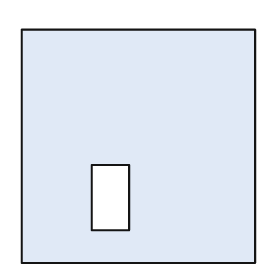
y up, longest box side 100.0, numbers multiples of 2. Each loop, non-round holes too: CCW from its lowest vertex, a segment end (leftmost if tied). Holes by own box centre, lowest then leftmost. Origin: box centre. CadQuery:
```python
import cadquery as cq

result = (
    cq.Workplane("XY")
    .moveTo(-50.0, -50.0)
    .lineTo(50.0, -50.0)
    .lineTo(50.0, 50.0)
    .lineTo(-50.0, 50.0)
    .close()
    .moveTo(-20.0, -36.0)
    .lineTo(-4.0, -36.0)
    .lineTo(-4.0, -8.0)
    .lineTo(-20.0, -8.0)
    .close()
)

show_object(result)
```